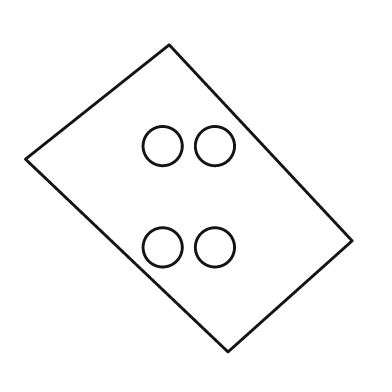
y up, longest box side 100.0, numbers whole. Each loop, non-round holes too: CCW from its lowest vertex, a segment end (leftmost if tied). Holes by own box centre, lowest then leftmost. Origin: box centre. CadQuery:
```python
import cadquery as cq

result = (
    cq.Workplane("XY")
    .moveTo(12.0, -47.0)
    .lineTo(50.0, -13.0)
    .lineTo(-6.0, 47.0)
    .lineTo(-50.0, 12.0)
    .close()
    .moveTo(-8.0, -15.0)
    .circle(6.0)
    .moveTo(8.0, -15.0)
    .circle(6.0)
    .moveTo(-8.0, 16.0)
    .circle(6.0)
    .moveTo(8.0, 16.0)
    .circle(6.0)
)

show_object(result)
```